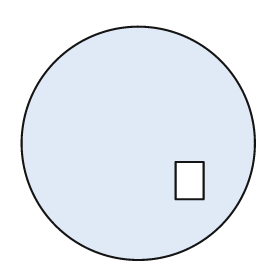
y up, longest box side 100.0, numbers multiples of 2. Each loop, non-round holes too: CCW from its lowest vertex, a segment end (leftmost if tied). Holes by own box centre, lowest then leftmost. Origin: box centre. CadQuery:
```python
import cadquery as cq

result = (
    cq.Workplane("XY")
    .moveTo(0.0, 0.0)
    .circle(50.0)
    .moveTo(16.0, -24.0)
    .lineTo(28.0, -24.0)
    .lineTo(28.0, -8.0)
    .lineTo(16.0, -8.0)
    .close()
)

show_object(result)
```